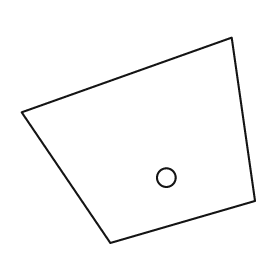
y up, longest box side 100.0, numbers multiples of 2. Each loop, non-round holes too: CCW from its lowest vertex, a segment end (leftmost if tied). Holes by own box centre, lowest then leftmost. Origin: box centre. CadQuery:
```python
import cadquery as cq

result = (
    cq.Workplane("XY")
    .moveTo(-12.0, -44.0)
    .lineTo(50.0, -26.0)
    .lineTo(40.0, 44.0)
    .lineTo(-50.0, 12.0)
    .close()
    .moveTo(12.0, -16.0)
    .circle(4.0)
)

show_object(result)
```